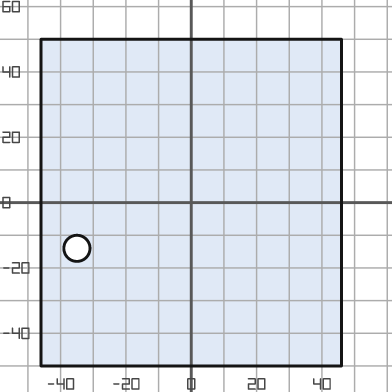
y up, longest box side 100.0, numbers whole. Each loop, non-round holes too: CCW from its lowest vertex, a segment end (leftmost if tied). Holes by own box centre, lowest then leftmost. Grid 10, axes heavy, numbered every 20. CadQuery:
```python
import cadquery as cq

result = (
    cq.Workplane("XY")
    .moveTo(-46.0, -50.0)
    .lineTo(46.0, -50.0)
    .lineTo(46.0, 50.0)
    .lineTo(-46.0, 50.0)
    .close()
    .moveTo(-35.0, -14.0)
    .circle(4.0)
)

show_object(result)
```